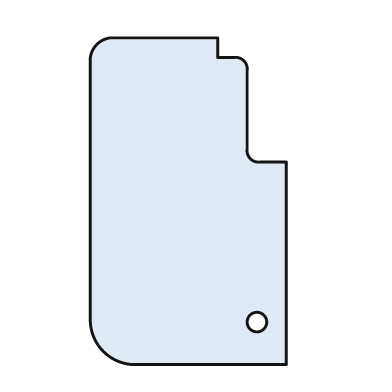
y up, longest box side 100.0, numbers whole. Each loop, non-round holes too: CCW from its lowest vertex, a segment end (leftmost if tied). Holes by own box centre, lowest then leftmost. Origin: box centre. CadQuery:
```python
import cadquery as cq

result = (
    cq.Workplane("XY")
    .moveTo(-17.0, -50.0)
    .lineTo(30.0, -50.0)
    .lineTo(30.0, 12.0)
    .lineTo(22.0, 12.0)
    .threePointArc((19.0, 13.0), (18.0, 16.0))
    .lineTo(18.0, 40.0)
    .threePointArc((17.0, 43.0), (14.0, 44.0))
    .lineTo(9.0, 44.0)
    .lineTo(9.0, 50.0)
    .lineTo(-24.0, 50.0)
    .threePointArc((-28.0, 48.0), (-30.0, 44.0))
    .lineTo(-30.0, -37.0)
    .threePointArc((-26.0, -46.0), (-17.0, -50.0))
    .close()
    .moveTo(21.0, -37.0)
    .circle(3.0)
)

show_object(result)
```